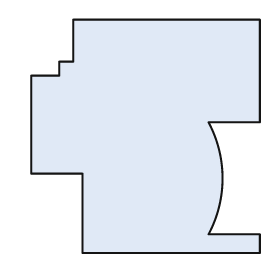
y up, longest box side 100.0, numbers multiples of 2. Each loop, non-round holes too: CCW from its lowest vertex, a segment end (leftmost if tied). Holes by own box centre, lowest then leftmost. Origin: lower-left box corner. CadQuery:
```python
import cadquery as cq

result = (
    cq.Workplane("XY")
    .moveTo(22.0, 0.0)
    .lineTo(98.0, 0.0)
    .lineTo(98.0, 8.0)
    .lineTo(76.0, 8.0)
    .threePointArc((82.0, 32.0), (76.0, 56.0))
    .lineTo(98.0, 56.0)
    .lineTo(98.0, 100.0)
    .lineTo(18.0, 100.0)
    .lineTo(18.0, 82.0)
    .lineTo(12.0, 82.0)
    .lineTo(12.0, 76.0)
    .lineTo(0.0, 76.0)
    .lineTo(0.0, 34.0)
    .lineTo(22.0, 34.0)
    .close()
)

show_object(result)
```